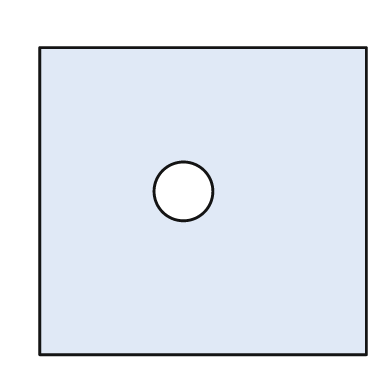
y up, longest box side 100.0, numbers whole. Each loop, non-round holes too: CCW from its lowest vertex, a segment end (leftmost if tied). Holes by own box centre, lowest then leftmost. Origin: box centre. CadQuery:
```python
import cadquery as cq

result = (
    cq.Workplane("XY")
    .moveTo(-50.0, -47.0)
    .lineTo(50.0, -47.0)
    .lineTo(50.0, 47.0)
    .lineTo(-50.0, 47.0)
    .close()
    .moveTo(-6.0, 3.0)
    .circle(9.0)
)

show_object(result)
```